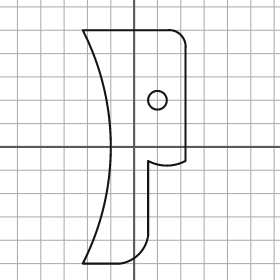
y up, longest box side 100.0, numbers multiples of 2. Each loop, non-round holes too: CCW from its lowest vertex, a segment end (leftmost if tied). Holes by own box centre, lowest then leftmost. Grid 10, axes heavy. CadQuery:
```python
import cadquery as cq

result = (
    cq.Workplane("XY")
    .moveTo(-22.0, -50.0)
    .lineTo(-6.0, -50.0)
    .threePointArc((2.0, -46.0), (6.0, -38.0))
    .lineTo(6.0, -6.0)
    .threePointArc((14.0, -8.0), (22.0, -6.0))
    .lineTo(22.0, 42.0)
    .threePointArc((20.0, 48.0), (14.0, 50.0))
    .lineTo(-22.0, 50.0)
    .threePointArc((-10.0, 0.0), (-22.0, -50.0))
    .close()
    .moveTo(10.0, 20.0)
    .circle(4.0)
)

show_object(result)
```